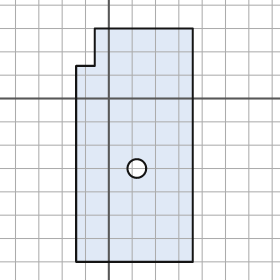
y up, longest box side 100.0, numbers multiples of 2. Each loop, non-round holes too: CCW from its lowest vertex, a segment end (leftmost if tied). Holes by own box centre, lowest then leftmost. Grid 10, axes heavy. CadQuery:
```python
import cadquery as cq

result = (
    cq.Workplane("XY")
    .moveTo(-14.0, -70.0)
    .lineTo(36.0, -70.0)
    .lineTo(36.0, 30.0)
    .lineTo(-6.0, 30.0)
    .lineTo(-6.0, 14.0)
    .lineTo(-14.0, 14.0)
    .close()
    .moveTo(12.0, -30.0)
    .circle(4.0)
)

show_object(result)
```